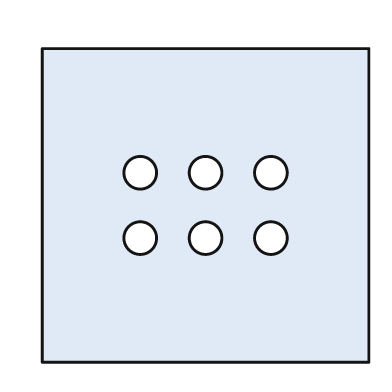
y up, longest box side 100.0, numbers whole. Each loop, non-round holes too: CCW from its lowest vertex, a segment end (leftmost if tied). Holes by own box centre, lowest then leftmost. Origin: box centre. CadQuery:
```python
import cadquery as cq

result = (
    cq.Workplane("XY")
    .moveTo(-50.0, -48.0)
    .lineTo(50.0, -48.0)
    .lineTo(50.0, 48.0)
    .lineTo(-50.0, 48.0)
    .close()
    .moveTo(-20.0, -10.0)
    .circle(5.0)
    .moveTo(0.0, -10.0)
    .circle(5.0)
    .moveTo(20.0, -10.0)
    .circle(5.0)
    .moveTo(-20.0, 10.0)
    .circle(5.0)
    .moveTo(0.0, 10.0)
    .circle(5.0)
    .moveTo(20.0, 10.0)
    .circle(5.0)
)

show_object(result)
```